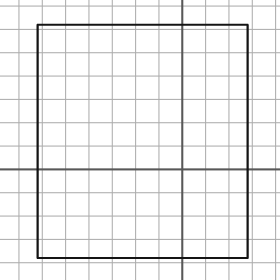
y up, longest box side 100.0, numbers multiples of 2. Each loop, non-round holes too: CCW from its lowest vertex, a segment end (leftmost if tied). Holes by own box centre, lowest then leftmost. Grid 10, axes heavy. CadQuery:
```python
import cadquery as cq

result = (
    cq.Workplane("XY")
    .moveTo(-62.0, -38.0)
    .lineTo(28.0, -38.0)
    .lineTo(28.0, 62.0)
    .lineTo(-62.0, 62.0)
    .close()
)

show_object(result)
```